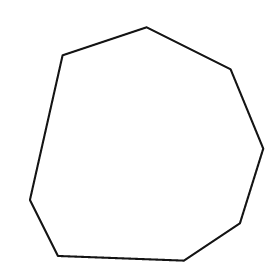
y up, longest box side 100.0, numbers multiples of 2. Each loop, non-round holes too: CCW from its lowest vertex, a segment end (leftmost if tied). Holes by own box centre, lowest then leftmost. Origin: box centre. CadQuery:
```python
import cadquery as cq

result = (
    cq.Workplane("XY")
    .moveTo(16.0, -50.0)
    .lineTo(40.0, -34.0)
    .lineTo(50.0, -2.0)
    .lineTo(36.0, 32.0)
    .lineTo(0.0, 50.0)
    .lineTo(-36.0, 38.0)
    .lineTo(-50.0, -24.0)
    .lineTo(-38.0, -48.0)
    .close()
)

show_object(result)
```